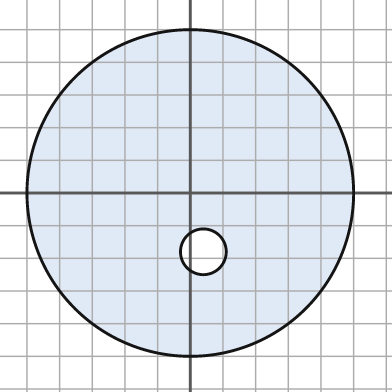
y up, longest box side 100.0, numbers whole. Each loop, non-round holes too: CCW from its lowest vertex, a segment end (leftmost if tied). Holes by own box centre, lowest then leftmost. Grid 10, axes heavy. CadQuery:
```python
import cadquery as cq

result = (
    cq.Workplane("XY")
    .moveTo(0.0, 0.0)
    .circle(50.0)
    .moveTo(4.0, -18.0)
    .circle(7.0)
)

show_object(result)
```